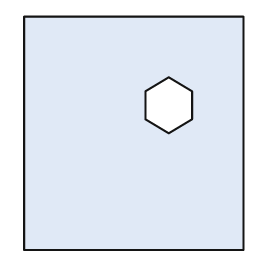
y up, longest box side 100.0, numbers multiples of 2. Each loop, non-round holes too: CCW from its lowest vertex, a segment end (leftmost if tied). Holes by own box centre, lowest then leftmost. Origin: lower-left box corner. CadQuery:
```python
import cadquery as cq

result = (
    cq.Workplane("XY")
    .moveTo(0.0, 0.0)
    .lineTo(94.0, 0.0)
    .lineTo(94.0, 100.0)
    .lineTo(0.0, 100.0)
    .close()
    .moveTo(62.0, 50.0)
    .lineTo(72.0, 56.0)
    .lineTo(72.0, 68.0)
    .lineTo(62.0, 74.0)
    .lineTo(52.0, 68.0)
    .lineTo(52.0, 56.0)
    .close()
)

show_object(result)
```